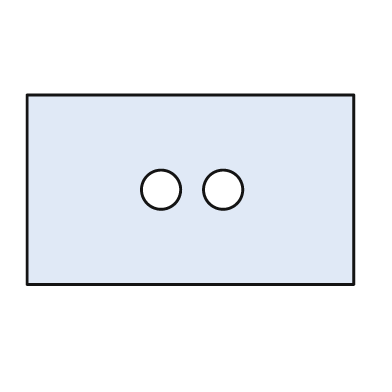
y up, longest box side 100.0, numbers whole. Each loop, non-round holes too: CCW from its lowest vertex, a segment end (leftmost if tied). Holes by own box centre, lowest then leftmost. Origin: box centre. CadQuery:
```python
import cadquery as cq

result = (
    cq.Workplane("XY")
    .moveTo(-50.0, -29.0)
    .lineTo(50.0, -29.0)
    .lineTo(50.0, 29.0)
    .lineTo(-50.0, 29.0)
    .close()
    .moveTo(-9.0, 0.0)
    .circle(6.0)
    .moveTo(10.0, 0.0)
    .circle(6.0)
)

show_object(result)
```